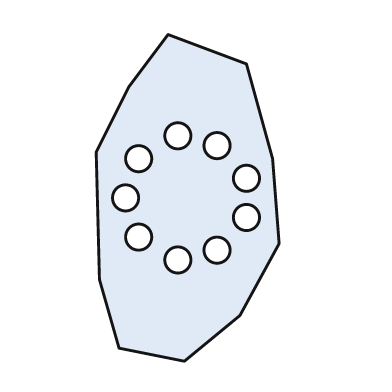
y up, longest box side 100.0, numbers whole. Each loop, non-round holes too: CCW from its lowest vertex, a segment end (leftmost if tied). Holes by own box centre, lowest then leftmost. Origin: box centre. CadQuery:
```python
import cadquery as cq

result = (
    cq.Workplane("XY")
    .moveTo(-1.0, -50.0)
    .lineTo(16.0, -36.0)
    .lineTo(28.0, -14.0)
    .lineTo(26.0, 12.0)
    .lineTo(18.0, 41.0)
    .lineTo(-6.0, 50.0)
    .lineTo(-18.0, 34.0)
    .lineTo(-28.0, 14.0)
    .lineTo(-27.0, -25.0)
    .lineTo(-21.0, -46.0)
    .close()
    .moveTo(-3.0, -19.0)
    .circle(4.0)
    .moveTo(9.0, -16.0)
    .circle(4.0)
    .moveTo(-15.0, -12.0)
    .circle(4.0)
    .moveTo(18.0, -6.0)
    .circle(4.0)
    .moveTo(-19.0, 0.0)
    .circle(4.0)
    .moveTo(18.0, 6.0)
    .circle(4.0)
    .moveTo(-15.0, 12.0)
    .circle(4.0)
    .moveTo(9.0, 16.0)
    .circle(4.0)
    .moveTo(-3.0, 19.0)
    .circle(4.0)
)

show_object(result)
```